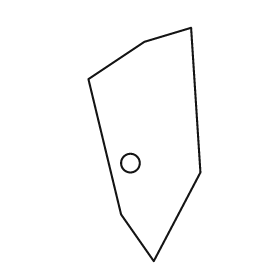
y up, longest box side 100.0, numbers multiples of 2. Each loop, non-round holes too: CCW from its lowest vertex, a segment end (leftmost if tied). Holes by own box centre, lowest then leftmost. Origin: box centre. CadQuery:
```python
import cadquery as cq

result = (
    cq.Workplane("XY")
    .moveTo(4.0, -50.0)
    .lineTo(24.0, -12.0)
    .lineTo(20.0, 50.0)
    .lineTo(0.0, 44.0)
    .lineTo(-24.0, 28.0)
    .lineTo(-10.0, -30.0)
    .close()
    .moveTo(-6.0, -8.0)
    .circle(4.0)
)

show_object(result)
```